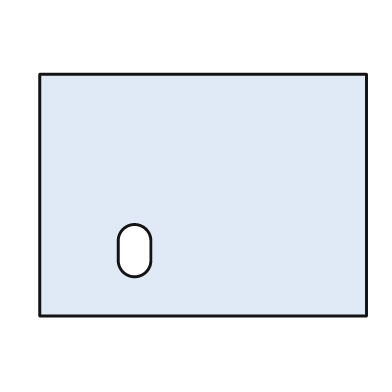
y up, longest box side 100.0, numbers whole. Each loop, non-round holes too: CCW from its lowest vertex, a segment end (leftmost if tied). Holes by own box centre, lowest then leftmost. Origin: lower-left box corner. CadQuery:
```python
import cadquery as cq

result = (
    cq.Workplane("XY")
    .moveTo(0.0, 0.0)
    .lineTo(100.0, 0.0)
    .lineTo(100.0, 74.0)
    .lineTo(0.0, 74.0)
    .close()
    .moveTo(24.0, 17.0)
    .threePointArc((29.0, 12.0), (34.0, 17.0))
    .lineTo(34.0, 23.0)
    .threePointArc((29.0, 28.0), (24.0, 23.0))
    .close()
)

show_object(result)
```